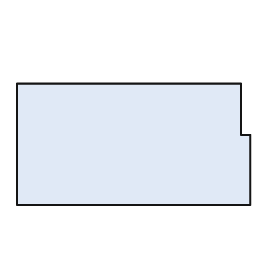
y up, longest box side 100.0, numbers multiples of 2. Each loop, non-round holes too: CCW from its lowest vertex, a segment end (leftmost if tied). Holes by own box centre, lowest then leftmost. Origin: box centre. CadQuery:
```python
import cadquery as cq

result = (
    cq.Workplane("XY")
    .moveTo(-50.0, -26.0)
    .lineTo(50.0, -26.0)
    .lineTo(50.0, 4.0)
    .lineTo(46.0, 4.0)
    .lineTo(46.0, 26.0)
    .lineTo(-50.0, 26.0)
    .close()
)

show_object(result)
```